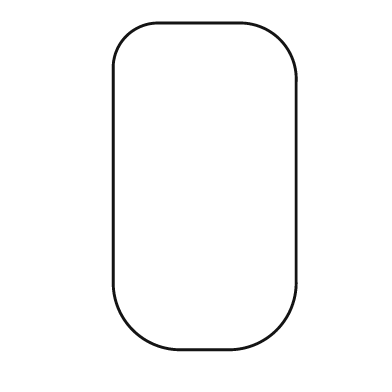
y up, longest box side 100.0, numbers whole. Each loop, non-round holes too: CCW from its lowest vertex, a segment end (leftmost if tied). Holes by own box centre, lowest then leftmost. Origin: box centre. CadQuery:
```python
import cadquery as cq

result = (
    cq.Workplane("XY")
    .moveTo(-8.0, -50.0)
    .lineTo(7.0, -50.0)
    .threePointArc((22.0, -44.0), (28.0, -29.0))
    .lineTo(28.0, 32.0)
    .threePointArc((23.0, 45.0), (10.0, 50.0))
    .lineTo(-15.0, 50.0)
    .threePointArc((-24.0, 46.0), (-28.0, 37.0))
    .lineTo(-28.0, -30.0)
    .threePointArc((-22.0, -44.0), (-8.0, -50.0))
    .close()
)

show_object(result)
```